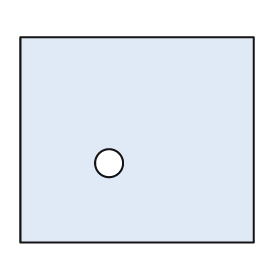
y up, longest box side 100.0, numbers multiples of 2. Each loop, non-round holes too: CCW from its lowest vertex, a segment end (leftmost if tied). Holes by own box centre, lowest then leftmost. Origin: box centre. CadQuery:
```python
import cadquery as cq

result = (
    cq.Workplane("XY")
    .moveTo(-50.0, -44.0)
    .lineTo(50.0, -44.0)
    .lineTo(50.0, 44.0)
    .lineTo(-50.0, 44.0)
    .close()
    .moveTo(-12.0, -10.0)
    .circle(6.0)
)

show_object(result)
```